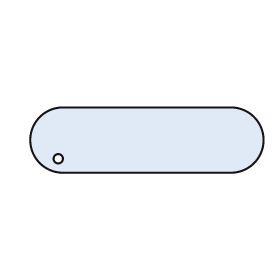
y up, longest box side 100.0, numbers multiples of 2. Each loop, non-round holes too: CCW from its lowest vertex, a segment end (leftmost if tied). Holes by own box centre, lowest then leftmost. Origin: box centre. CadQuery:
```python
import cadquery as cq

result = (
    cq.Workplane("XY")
    .moveTo(-36.0, -14.0)
    .lineTo(36.0, -14.0)
    .threePointArc((50.0, 0.0), (36.0, 14.0))
    .lineTo(-36.0, 14.0)
    .threePointArc((-50.0, 0.0), (-36.0, -14.0))
    .close()
    .moveTo(-38.0, -8.0)
    .circle(2.0)
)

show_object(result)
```